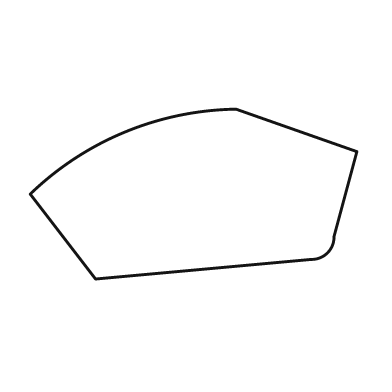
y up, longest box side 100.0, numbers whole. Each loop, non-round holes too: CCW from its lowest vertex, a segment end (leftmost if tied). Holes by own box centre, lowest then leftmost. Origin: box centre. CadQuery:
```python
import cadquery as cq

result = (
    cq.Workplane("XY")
    .moveTo(-30.0, -26.0)
    .lineTo(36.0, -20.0)
    .threePointArc((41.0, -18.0), (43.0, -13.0))
    .lineTo(50.0, 13.0)
    .lineTo(13.0, 26.0)
    .threePointArc((-21.0, 19.0), (-50.0, 0.0))
    .close()
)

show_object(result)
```